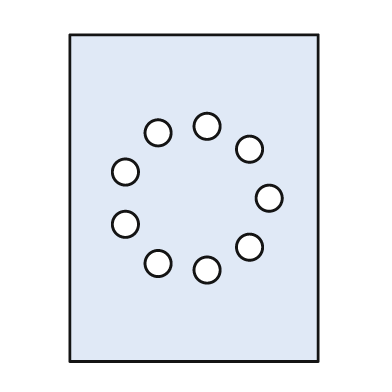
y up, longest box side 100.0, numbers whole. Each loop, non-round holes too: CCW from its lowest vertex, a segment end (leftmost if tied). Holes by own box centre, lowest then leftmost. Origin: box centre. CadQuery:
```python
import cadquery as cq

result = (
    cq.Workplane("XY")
    .moveTo(-38.0, -50.0)
    .lineTo(38.0, -50.0)
    .lineTo(38.0, 50.0)
    .lineTo(-38.0, 50.0)
    .close()
    .moveTo(4.0, -22.0)
    .circle(4.0)
    .moveTo(-11.0, -20.0)
    .circle(4.0)
    .moveTo(17.0, -15.0)
    .circle(4.0)
    .moveTo(-21.0, -8.0)
    .circle(4.0)
    .moveTo(23.0, 0.0)
    .circle(4.0)
    .moveTo(-21.0, 8.0)
    .circle(4.0)
    .moveTo(17.0, 15.0)
    .circle(4.0)
    .moveTo(-11.0, 20.0)
    .circle(4.0)
    .moveTo(4.0, 22.0)
    .circle(4.0)
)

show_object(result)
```